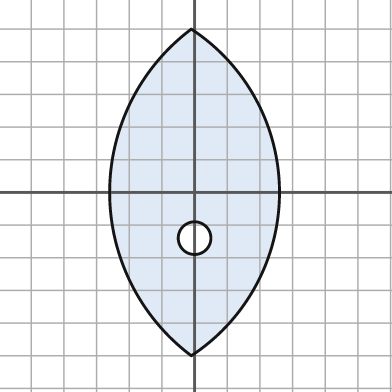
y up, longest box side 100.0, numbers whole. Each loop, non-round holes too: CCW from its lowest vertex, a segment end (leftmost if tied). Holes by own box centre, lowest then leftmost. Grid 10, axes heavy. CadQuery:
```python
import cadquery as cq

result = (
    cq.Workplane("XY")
    .moveTo(-1.0, -50.0)
    .threePointArc((26.0, 0.0), (-1.0, 50.0))
    .threePointArc((-26.0, 0.0), (-1.0, -50.0))
    .close()
    .moveTo(0.0, -14.0)
    .circle(5.0)
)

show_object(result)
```